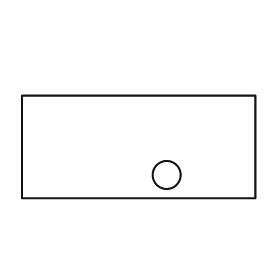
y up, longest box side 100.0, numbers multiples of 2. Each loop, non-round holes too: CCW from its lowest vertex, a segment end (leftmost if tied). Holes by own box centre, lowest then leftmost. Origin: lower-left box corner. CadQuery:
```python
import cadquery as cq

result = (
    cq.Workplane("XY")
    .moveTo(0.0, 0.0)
    .lineTo(100.0, 0.0)
    .lineTo(100.0, 44.0)
    .lineTo(0.0, 44.0)
    .close()
    .moveTo(62.0, 10.0)
    .circle(6.0)
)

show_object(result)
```